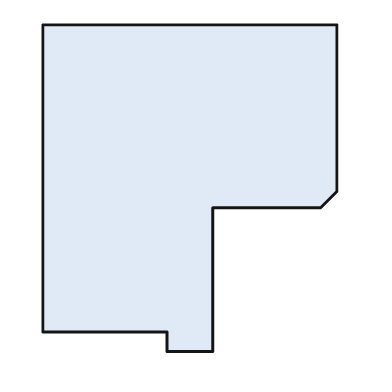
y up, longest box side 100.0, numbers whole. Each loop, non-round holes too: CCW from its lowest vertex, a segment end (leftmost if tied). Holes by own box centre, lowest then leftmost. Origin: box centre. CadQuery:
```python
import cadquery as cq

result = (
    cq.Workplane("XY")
    .moveTo(-7.0, -50.0)
    .lineTo(7.0, -50.0)
    .lineTo(7.0, -6.0)
    .lineTo(40.0, -6.0)
    .lineTo(45.0, -1.0)
    .lineTo(45.0, 50.0)
    .lineTo(-45.0, 50.0)
    .lineTo(-45.0, -44.0)
    .lineTo(-7.0, -44.0)
    .close()
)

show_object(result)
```